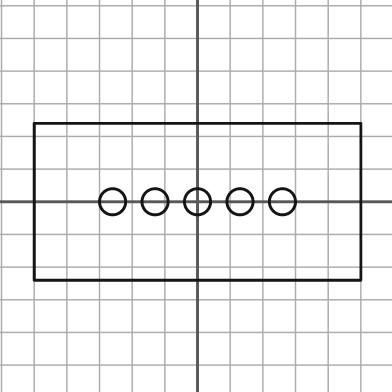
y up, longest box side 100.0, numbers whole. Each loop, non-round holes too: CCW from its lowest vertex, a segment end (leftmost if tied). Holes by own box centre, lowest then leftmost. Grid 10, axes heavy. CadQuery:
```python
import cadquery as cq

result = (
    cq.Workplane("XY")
    .moveTo(-50.0, -24.0)
    .lineTo(50.0, -24.0)
    .lineTo(50.0, 24.0)
    .lineTo(-50.0, 24.0)
    .close()
    .moveTo(-26.0, 0.0)
    .circle(4.0)
    .moveTo(-13.0, 0.0)
    .circle(4.0)
    .moveTo(0.0, 0.0)
    .circle(4.0)
    .moveTo(13.0, 0.0)
    .circle(4.0)
    .moveTo(26.0, 0.0)
    .circle(4.0)
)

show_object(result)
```